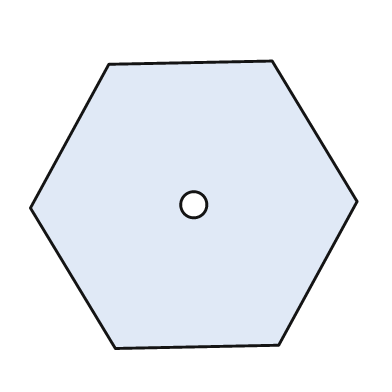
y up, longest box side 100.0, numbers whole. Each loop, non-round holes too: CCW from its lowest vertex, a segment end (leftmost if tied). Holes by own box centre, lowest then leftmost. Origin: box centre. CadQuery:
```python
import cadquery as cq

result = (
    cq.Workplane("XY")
    .moveTo(-24.0, -44.0)
    .lineTo(26.0, -43.0)
    .lineTo(50.0, 1.0)
    .lineTo(24.0, 44.0)
    .lineTo(-26.0, 43.0)
    .lineTo(-50.0, -1.0)
    .close()
    .moveTo(0.0, 0.0)
    .circle(4.0)
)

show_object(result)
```